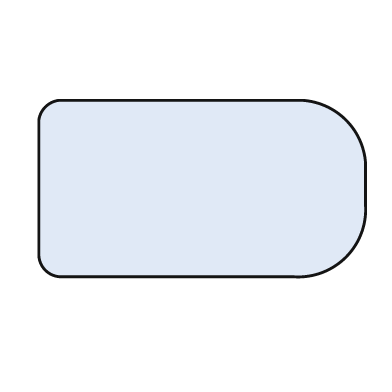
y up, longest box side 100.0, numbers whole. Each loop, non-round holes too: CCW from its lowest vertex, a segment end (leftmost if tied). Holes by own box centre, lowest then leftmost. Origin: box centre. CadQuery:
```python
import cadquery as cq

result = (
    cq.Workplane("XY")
    .moveTo(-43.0, -27.0)
    .lineTo(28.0, -27.0)
    .threePointArc((44.0, -21.0), (50.0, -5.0))
    .lineTo(50.0, 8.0)
    .threePointArc((44.0, 21.0), (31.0, 27.0))
    .lineTo(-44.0, 27.0)
    .threePointArc((-48.0, 25.0), (-50.0, 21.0))
    .lineTo(-50.0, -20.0)
    .threePointArc((-48.0, -25.0), (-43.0, -27.0))
    .close()
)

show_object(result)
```